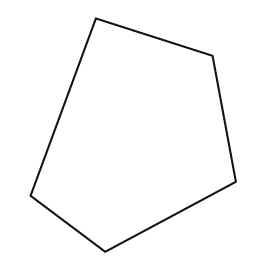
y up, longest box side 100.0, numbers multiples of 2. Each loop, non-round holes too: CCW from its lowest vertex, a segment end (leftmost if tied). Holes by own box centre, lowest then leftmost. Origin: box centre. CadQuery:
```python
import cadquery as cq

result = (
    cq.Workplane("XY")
    .moveTo(-12.0, -50.0)
    .lineTo(44.0, -20.0)
    .lineTo(34.0, 34.0)
    .lineTo(-16.0, 50.0)
    .lineTo(-44.0, -26.0)
    .close()
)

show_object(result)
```